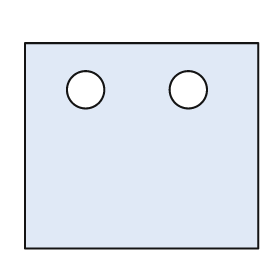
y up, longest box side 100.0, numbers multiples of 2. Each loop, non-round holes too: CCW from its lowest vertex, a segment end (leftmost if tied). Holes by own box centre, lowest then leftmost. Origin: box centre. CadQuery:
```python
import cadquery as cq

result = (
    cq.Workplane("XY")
    .moveTo(-50.0, -44.0)
    .lineTo(50.0, -44.0)
    .lineTo(50.0, 44.0)
    .lineTo(-50.0, 44.0)
    .close()
    .moveTo(-24.0, 24.0)
    .circle(8.0)
    .moveTo(20.0, 24.0)
    .circle(8.0)
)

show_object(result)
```